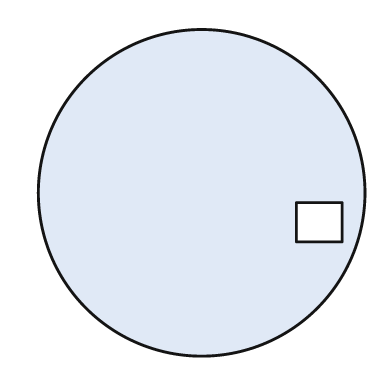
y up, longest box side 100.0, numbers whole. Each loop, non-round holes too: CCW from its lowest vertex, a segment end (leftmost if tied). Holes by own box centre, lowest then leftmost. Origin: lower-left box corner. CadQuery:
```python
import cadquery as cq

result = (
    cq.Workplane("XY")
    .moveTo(50.0, 50.0)
    .circle(50.0)
    .moveTo(79.0, 35.0)
    .lineTo(93.0, 35.0)
    .lineTo(93.0, 47.0)
    .lineTo(79.0, 47.0)
    .close()
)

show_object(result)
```